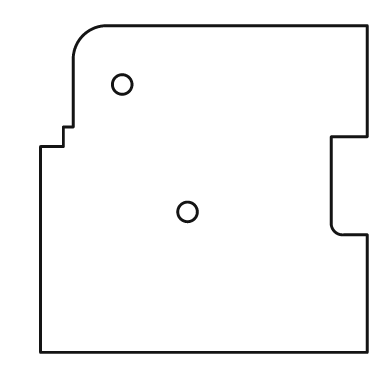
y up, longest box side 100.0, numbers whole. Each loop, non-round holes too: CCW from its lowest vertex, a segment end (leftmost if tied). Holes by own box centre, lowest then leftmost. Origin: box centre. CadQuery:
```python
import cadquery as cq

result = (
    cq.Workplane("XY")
    .moveTo(-50.0, -50.0)
    .lineTo(50.0, -50.0)
    .lineTo(50.0, -14.0)
    .lineTo(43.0, -14.0)
    .threePointArc((40.0, -13.0), (39.0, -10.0))
    .lineTo(39.0, 16.0)
    .lineTo(50.0, 16.0)
    .lineTo(50.0, 50.0)
    .lineTo(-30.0, 50.0)
    .threePointArc((-37.0, 47.0), (-40.0, 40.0))
    .lineTo(-40.0, 19.0)
    .lineTo(-43.0, 19.0)
    .lineTo(-43.0, 13.0)
    .lineTo(-50.0, 13.0)
    .close()
    .moveTo(-5.0, -7.0)
    .circle(3.0)
    .moveTo(-25.0, 32.0)
    .circle(3.0)
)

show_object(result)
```